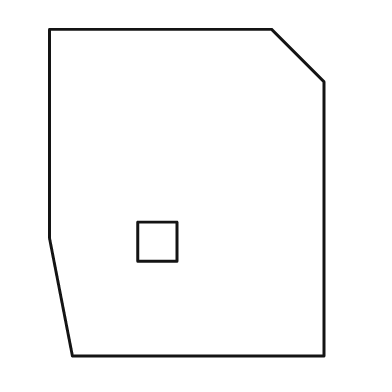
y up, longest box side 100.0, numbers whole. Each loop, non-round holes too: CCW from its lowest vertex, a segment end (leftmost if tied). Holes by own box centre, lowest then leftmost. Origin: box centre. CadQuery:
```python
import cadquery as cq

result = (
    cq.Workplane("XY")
    .moveTo(-35.0, -50.0)
    .lineTo(42.0, -50.0)
    .lineTo(42.0, 34.0)
    .lineTo(26.0, 50.0)
    .lineTo(-42.0, 50.0)
    .lineTo(-42.0, -14.0)
    .close()
    .moveTo(-15.0, -21.0)
    .lineTo(-3.0, -21.0)
    .lineTo(-3.0, -9.0)
    .lineTo(-15.0, -9.0)
    .close()
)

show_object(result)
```